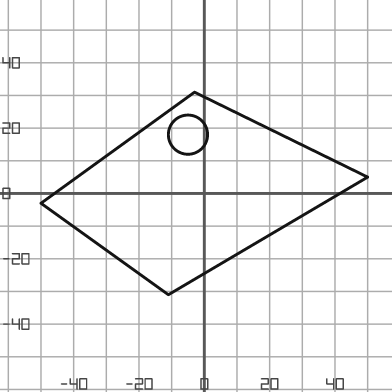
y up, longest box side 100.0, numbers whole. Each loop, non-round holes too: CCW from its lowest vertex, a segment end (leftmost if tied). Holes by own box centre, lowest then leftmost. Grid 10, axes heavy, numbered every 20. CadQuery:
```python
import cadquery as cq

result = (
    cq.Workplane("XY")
    .moveTo(-11.0, -31.0)
    .lineTo(50.0, 5.0)
    .lineTo(-3.0, 31.0)
    .lineTo(-50.0, -3.0)
    .close()
    .moveTo(-5.0, 18.0)
    .circle(6.0)
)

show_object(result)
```